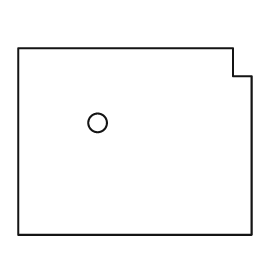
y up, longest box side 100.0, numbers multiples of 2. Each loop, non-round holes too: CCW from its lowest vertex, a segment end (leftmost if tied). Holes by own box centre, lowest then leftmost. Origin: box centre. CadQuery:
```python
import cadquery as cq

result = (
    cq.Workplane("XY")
    .moveTo(-50.0, -40.0)
    .lineTo(50.0, -40.0)
    .lineTo(50.0, 28.0)
    .lineTo(42.0, 28.0)
    .lineTo(42.0, 40.0)
    .lineTo(-50.0, 40.0)
    .close()
    .moveTo(-16.0, 8.0)
    .circle(4.0)
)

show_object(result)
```